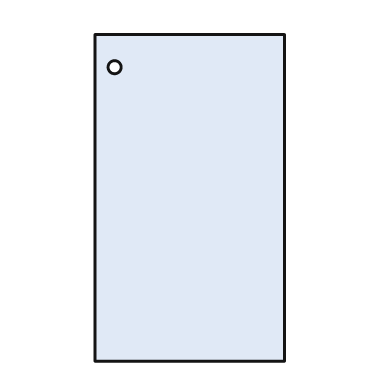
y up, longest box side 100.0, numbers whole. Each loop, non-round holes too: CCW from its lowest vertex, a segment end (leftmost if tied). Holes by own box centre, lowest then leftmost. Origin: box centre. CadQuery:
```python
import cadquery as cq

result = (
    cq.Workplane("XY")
    .moveTo(-29.0, -50.0)
    .lineTo(29.0, -50.0)
    .lineTo(29.0, 50.0)
    .lineTo(-29.0, 50.0)
    .close()
    .moveTo(-23.0, 40.0)
    .circle(2.0)
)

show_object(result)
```